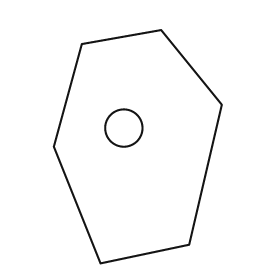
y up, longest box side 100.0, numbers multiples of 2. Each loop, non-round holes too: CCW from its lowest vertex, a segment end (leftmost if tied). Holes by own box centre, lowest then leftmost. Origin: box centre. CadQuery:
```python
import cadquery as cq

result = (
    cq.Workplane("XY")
    .moveTo(-16.0, -50.0)
    .lineTo(22.0, -42.0)
    .lineTo(36.0, 18.0)
    .lineTo(10.0, 50.0)
    .lineTo(-24.0, 44.0)
    .lineTo(-36.0, 0.0)
    .close()
    .moveTo(-6.0, 8.0)
    .circle(8.0)
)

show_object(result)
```